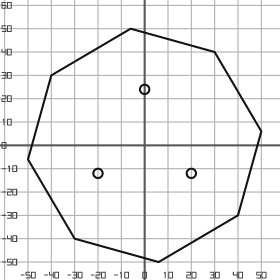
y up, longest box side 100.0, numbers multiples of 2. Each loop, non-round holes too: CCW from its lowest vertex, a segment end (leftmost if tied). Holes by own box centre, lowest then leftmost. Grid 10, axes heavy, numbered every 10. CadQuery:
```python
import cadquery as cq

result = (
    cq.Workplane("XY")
    .moveTo(6.0, -50.0)
    .lineTo(40.0, -30.0)
    .lineTo(50.0, 6.0)
    .lineTo(30.0, 40.0)
    .lineTo(-6.0, 50.0)
    .lineTo(-40.0, 30.0)
    .lineTo(-50.0, -6.0)
    .lineTo(-30.0, -40.0)
    .close()
    .moveTo(-20.0, -12.0)
    .circle(2.0)
    .moveTo(20.0, -12.0)
    .circle(2.0)
    .moveTo(0.0, 24.0)
    .circle(2.0)
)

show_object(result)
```